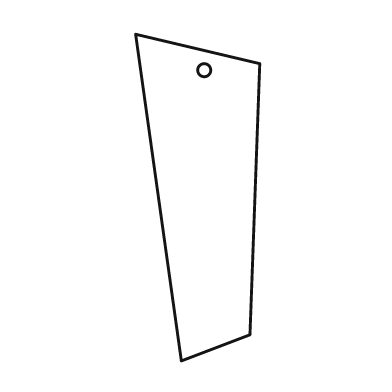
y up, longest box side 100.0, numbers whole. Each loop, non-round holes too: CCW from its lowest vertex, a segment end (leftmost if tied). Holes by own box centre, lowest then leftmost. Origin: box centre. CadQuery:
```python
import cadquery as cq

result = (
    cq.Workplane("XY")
    .moveTo(-5.0, -50.0)
    .lineTo(16.0, -42.0)
    .lineTo(19.0, 41.0)
    .lineTo(-19.0, 50.0)
    .close()
    .moveTo(2.0, 39.0)
    .circle(2.0)
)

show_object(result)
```